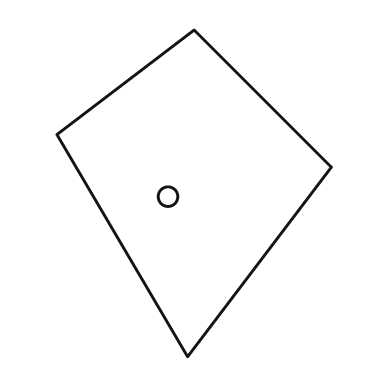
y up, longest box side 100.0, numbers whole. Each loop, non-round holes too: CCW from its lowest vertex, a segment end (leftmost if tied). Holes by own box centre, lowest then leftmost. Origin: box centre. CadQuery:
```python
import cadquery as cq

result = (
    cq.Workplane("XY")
    .moveTo(-2.0, -50.0)
    .lineTo(42.0, 8.0)
    .lineTo(0.0, 50.0)
    .lineTo(-42.0, 18.0)
    .close()
    .moveTo(-8.0, -1.0)
    .circle(3.0)
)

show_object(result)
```